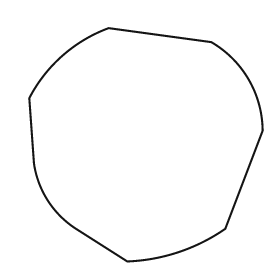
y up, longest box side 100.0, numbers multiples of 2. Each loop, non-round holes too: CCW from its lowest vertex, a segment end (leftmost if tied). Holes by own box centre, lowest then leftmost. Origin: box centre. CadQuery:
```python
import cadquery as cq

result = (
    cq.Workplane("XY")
    .moveTo(-8.0, -50.0)
    .threePointArc((14.0, -46.0), (34.0, -36.0))
    .lineTo(50.0, 6.0)
    .threePointArc((44.0, 28.0), (28.0, 44.0))
    .lineTo(-16.0, 50.0)
    .threePointArc((-36.0, 38.0), (-50.0, 20.0))
    .lineTo(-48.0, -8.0)
    .threePointArc((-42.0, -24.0), (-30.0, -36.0))
    .close()
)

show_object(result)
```